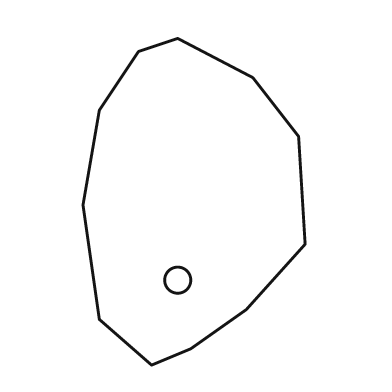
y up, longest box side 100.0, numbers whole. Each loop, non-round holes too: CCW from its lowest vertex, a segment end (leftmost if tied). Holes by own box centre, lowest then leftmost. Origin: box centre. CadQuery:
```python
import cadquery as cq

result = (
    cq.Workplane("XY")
    .moveTo(-13.0, -50.0)
    .lineTo(-1.0, -45.0)
    .lineTo(16.0, -33.0)
    .lineTo(34.0, -13.0)
    .lineTo(32.0, 20.0)
    .lineTo(18.0, 38.0)
    .lineTo(-5.0, 50.0)
    .lineTo(-17.0, 46.0)
    .lineTo(-29.0, 28.0)
    .lineTo(-34.0, -1.0)
    .lineTo(-29.0, -36.0)
    .close()
    .moveTo(-5.0, -24.0)
    .circle(4.0)
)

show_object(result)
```